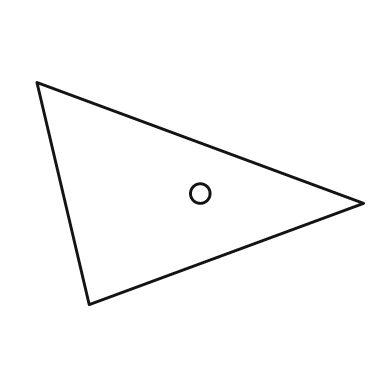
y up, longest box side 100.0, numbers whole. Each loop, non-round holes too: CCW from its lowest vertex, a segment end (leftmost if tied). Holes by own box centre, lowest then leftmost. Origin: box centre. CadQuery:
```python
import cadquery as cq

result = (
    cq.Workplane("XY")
    .moveTo(-34.0, -34.0)
    .lineTo(50.0, -3.0)
    .lineTo(-50.0, 34.0)
    .close()
    .moveTo(0.0, 0.0)
    .circle(3.0)
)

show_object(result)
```